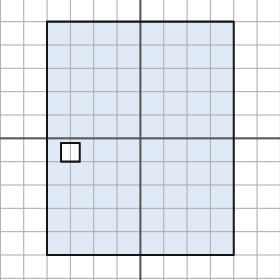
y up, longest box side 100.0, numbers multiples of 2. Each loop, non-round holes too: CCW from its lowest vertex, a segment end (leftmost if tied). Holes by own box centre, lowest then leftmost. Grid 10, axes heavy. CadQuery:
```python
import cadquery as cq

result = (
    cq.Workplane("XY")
    .moveTo(-40.0, -50.0)
    .lineTo(40.0, -50.0)
    .lineTo(40.0, 50.0)
    .lineTo(-40.0, 50.0)
    .close()
    .moveTo(-34.0, -10.0)
    .lineTo(-26.0, -10.0)
    .lineTo(-26.0, -2.0)
    .lineTo(-34.0, -2.0)
    .close()
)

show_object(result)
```